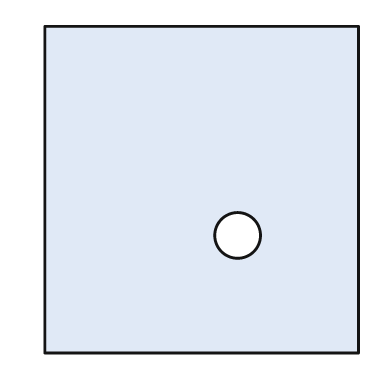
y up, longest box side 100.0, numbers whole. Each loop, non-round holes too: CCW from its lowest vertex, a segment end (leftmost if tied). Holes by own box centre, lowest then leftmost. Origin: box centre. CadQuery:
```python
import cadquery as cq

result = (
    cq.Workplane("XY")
    .moveTo(-48.0, -50.0)
    .lineTo(48.0, -50.0)
    .lineTo(48.0, 50.0)
    .lineTo(-48.0, 50.0)
    .close()
    .moveTo(11.0, -14.0)
    .circle(7.0)
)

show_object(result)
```